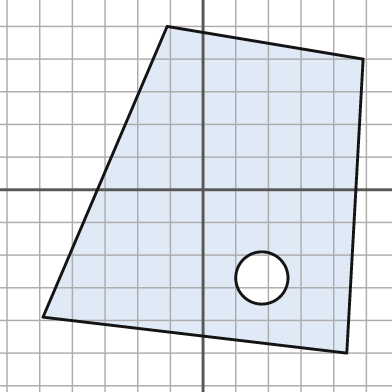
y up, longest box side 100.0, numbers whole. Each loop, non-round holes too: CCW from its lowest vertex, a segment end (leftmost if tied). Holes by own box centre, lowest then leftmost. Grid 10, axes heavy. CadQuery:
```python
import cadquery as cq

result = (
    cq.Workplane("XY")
    .moveTo(44.0, -50.0)
    .lineTo(49.0, 40.0)
    .lineTo(-11.0, 50.0)
    .lineTo(-49.0, -39.0)
    .close()
    .moveTo(18.0, -27.0)
    .circle(8.0)
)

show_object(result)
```